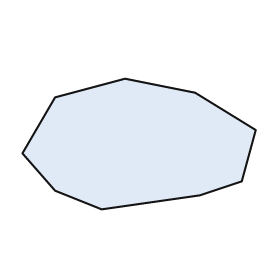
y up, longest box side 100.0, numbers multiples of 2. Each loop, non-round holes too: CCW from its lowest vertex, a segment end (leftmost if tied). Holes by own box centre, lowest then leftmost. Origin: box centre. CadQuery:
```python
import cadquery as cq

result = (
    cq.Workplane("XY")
    .moveTo(-16.0, -28.0)
    .lineTo(26.0, -22.0)
    .lineTo(44.0, -16.0)
    .lineTo(50.0, 6.0)
    .lineTo(24.0, 22.0)
    .lineTo(-6.0, 28.0)
    .lineTo(-36.0, 20.0)
    .lineTo(-50.0, -4.0)
    .lineTo(-36.0, -20.0)
    .close()
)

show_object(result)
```